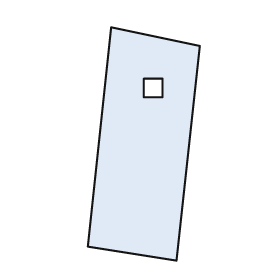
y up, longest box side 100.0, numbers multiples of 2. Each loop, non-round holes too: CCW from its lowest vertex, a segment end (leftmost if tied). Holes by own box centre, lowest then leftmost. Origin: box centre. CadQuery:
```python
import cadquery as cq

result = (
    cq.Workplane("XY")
    .moveTo(14.0, -50.0)
    .lineTo(24.0, 42.0)
    .lineTo(-14.0, 50.0)
    .lineTo(-24.0, -44.0)
    .close()
    .moveTo(0.0, 20.0)
    .lineTo(8.0, 20.0)
    .lineTo(8.0, 28.0)
    .lineTo(0.0, 28.0)
    .close()
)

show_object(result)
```